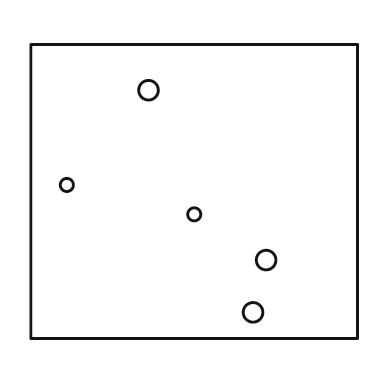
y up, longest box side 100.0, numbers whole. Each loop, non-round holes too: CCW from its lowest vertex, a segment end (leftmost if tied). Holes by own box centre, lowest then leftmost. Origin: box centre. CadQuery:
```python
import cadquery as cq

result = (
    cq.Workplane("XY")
    .moveTo(-50.0, -45.0)
    .lineTo(50.0, -45.0)
    .lineTo(50.0, 45.0)
    .lineTo(-50.0, 45.0)
    .close()
    .moveTo(18.0, -37.0)
    .circle(3.0)
    .moveTo(22.0, -21.0)
    .circle(3.0)
    .moveTo(0.0, -7.0)
    .circle(2.0)
    .moveTo(-39.0, 2.0)
    .circle(2.0)
    .moveTo(-14.0, 31.0)
    .circle(3.0)
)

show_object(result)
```